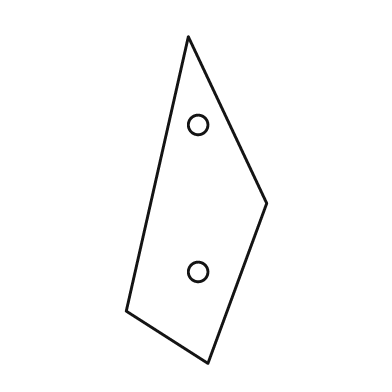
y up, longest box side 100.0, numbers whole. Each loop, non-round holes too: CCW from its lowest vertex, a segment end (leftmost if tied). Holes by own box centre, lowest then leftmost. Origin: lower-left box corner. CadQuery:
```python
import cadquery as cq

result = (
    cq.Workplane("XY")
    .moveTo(25.0, 0.0)
    .lineTo(43.0, 49.0)
    .lineTo(19.0, 100.0)
    .lineTo(0.0, 16.0)
    .close()
    .moveTo(22.0, 28.0)
    .circle(3.0)
    .moveTo(22.0, 73.0)
    .circle(3.0)
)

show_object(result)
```